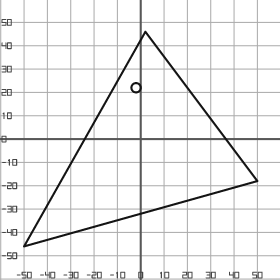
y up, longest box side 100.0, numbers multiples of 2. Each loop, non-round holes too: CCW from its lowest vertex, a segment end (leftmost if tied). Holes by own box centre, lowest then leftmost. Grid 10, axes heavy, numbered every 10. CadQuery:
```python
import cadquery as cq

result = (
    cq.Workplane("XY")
    .moveTo(-50.0, -46.0)
    .lineTo(50.0, -18.0)
    .lineTo(2.0, 46.0)
    .close()
    .moveTo(-2.0, 22.0)
    .circle(2.0)
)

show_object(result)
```